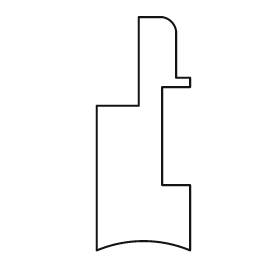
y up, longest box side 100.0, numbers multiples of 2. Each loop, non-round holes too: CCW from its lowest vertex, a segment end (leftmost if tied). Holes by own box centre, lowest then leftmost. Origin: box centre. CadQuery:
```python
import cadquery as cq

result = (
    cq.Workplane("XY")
    .moveTo(-20.0, -50.0)
    .threePointArc((0.0, -46.0), (20.0, -50.0))
    .lineTo(20.0, -22.0)
    .lineTo(8.0, -22.0)
    .lineTo(8.0, 20.0)
    .lineTo(20.0, 20.0)
    .lineTo(20.0, 24.0)
    .lineTo(14.0, 24.0)
    .lineTo(14.0, 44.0)
    .threePointArc((12.0, 48.0), (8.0, 50.0))
    .lineTo(-2.0, 50.0)
    .lineTo(-2.0, 12.0)
    .lineTo(-20.0, 12.0)
    .close()
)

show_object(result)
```